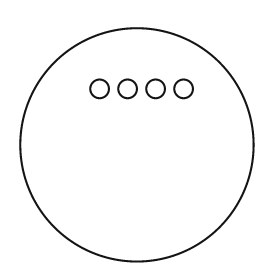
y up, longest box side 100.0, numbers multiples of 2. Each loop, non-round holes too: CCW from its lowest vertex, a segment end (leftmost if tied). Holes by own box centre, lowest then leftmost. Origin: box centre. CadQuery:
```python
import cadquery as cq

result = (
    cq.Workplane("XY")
    .moveTo(0.0, 0.0)
    .circle(50.0)
    .moveTo(-16.0, 24.0)
    .circle(4.0)
    .moveTo(-4.0, 24.0)
    .circle(4.0)
    .moveTo(8.0, 24.0)
    .circle(4.0)
    .moveTo(20.0, 24.0)
    .circle(4.0)
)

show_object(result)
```